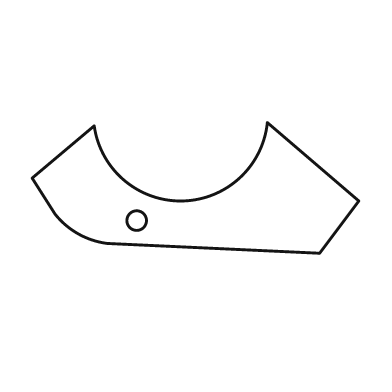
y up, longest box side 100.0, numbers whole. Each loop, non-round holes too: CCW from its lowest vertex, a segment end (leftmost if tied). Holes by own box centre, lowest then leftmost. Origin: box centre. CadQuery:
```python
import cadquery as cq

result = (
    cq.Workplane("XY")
    .moveTo(38.0, -20.0)
    .lineTo(50.0, -4.0)
    .lineTo(22.0, 20.0)
    .threePointArc((-4.0, -4.0), (-31.0, 19.0))
    .lineTo(-50.0, 3.0)
    .lineTo(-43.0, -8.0)
    .threePointArc((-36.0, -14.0), (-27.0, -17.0))
    .close()
    .moveTo(-18.0, -10.0)
    .circle(3.0)
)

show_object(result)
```